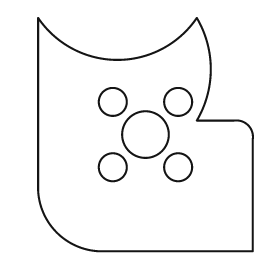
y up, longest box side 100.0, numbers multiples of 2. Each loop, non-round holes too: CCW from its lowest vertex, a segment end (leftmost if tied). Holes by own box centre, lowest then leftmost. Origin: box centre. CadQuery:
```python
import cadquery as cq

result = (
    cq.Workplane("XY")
    .moveTo(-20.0, -50.0)
    .lineTo(46.0, -50.0)
    .lineTo(46.0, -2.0)
    .threePointArc((44.0, 4.0), (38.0, 6.0))
    .lineTo(22.0, 6.0)
    .threePointArc((28.0, 28.0), (22.0, 50.0))
    .threePointArc((-12.0, 32.0), (-46.0, 50.0))
    .lineTo(-46.0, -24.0)
    .threePointArc((-38.0, -42.0), (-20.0, -50.0))
    .close()
    .moveTo(-14.0, -14.0)
    .circle(6.0)
    .moveTo(14.0, -14.0)
    .circle(6.0)
    .moveTo(0.0, 0.0)
    .circle(10.0)
    .moveTo(-14.0, 14.0)
    .circle(6.0)
    .moveTo(14.0, 14.0)
    .circle(6.0)
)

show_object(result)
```